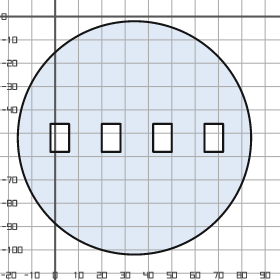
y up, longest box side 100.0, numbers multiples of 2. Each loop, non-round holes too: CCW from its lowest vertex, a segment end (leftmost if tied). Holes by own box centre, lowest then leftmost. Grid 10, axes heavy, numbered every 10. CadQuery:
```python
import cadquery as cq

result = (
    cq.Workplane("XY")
    .moveTo(34.0, -52.0)
    .circle(50.0)
    .moveTo(-2.0, -58.0)
    .lineTo(6.0, -58.0)
    .lineTo(6.0, -46.0)
    .lineTo(-2.0, -46.0)
    .close()
    .moveTo(20.0, -58.0)
    .lineTo(28.0, -58.0)
    .lineTo(28.0, -46.0)
    .lineTo(20.0, -46.0)
    .close()
    .moveTo(42.0, -58.0)
    .lineTo(50.0, -58.0)
    .lineTo(50.0, -46.0)
    .lineTo(42.0, -46.0)
    .close()
    .moveTo(64.0, -58.0)
    .lineTo(72.0, -58.0)
    .lineTo(72.0, -46.0)
    .lineTo(64.0, -46.0)
    .close()
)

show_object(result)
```